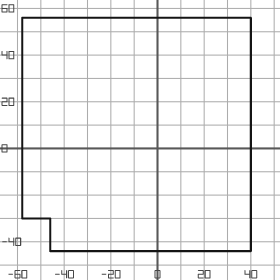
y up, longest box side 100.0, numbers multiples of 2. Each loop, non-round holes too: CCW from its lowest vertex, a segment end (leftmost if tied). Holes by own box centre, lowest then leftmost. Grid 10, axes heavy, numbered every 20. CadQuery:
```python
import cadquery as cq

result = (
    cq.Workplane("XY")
    .moveTo(-46.0, -44.0)
    .lineTo(40.0, -44.0)
    .lineTo(40.0, 56.0)
    .lineTo(-58.0, 56.0)
    .lineTo(-58.0, -30.0)
    .lineTo(-46.0, -30.0)
    .close()
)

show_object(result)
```